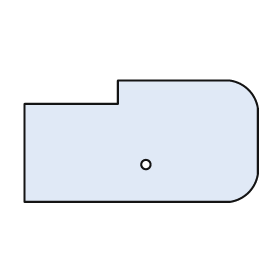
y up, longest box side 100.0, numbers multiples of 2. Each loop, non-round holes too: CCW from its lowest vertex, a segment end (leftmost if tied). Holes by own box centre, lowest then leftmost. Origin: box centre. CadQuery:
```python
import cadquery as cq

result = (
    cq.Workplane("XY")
    .moveTo(-50.0, -26.0)
    .lineTo(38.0, -26.0)
    .threePointArc((46.0, -22.0), (50.0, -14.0))
    .lineTo(50.0, 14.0)
    .threePointArc((46.0, 22.0), (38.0, 26.0))
    .lineTo(-10.0, 26.0)
    .lineTo(-10.0, 16.0)
    .lineTo(-50.0, 16.0)
    .close()
    .moveTo(2.0, -10.0)
    .circle(2.0)
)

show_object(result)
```